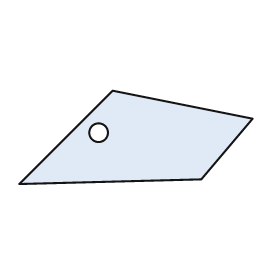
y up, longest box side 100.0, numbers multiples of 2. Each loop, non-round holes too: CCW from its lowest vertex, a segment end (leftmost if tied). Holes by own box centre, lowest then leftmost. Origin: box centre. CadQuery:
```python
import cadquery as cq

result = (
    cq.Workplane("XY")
    .moveTo(-50.0, -20.0)
    .lineTo(28.0, -18.0)
    .lineTo(50.0, 8.0)
    .lineTo(-10.0, 20.0)
    .close()
    .moveTo(-16.0, 2.0)
    .circle(4.0)
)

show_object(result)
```